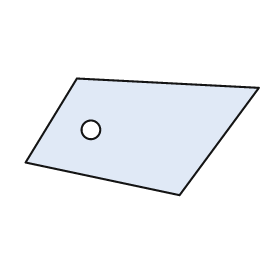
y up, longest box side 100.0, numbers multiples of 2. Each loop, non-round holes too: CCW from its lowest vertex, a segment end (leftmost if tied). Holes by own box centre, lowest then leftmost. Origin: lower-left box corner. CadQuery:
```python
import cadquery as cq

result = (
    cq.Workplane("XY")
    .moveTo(66.0, 0.0)
    .lineTo(100.0, 46.0)
    .lineTo(22.0, 50.0)
    .lineTo(0.0, 14.0)
    .close()
    .moveTo(28.0, 28.0)
    .circle(4.0)
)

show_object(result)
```